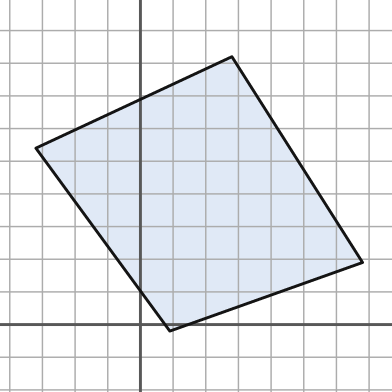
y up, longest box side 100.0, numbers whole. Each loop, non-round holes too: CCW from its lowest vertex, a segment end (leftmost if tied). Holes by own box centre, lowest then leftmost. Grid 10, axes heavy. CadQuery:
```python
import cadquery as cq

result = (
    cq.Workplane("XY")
    .moveTo(9.0, -2.0)
    .lineTo(68.0, 19.0)
    .lineTo(28.0, 82.0)
    .lineTo(-32.0, 54.0)
    .close()
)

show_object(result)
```